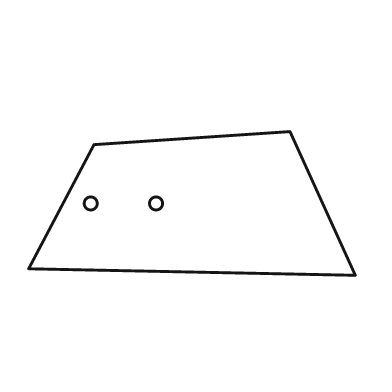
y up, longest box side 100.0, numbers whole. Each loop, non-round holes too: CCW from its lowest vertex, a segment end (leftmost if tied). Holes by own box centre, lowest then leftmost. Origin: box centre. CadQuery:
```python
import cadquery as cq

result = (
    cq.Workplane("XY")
    .moveTo(50.0, -22.0)
    .lineTo(30.0, 22.0)
    .lineTo(-30.0, 18.0)
    .lineTo(-50.0, -20.0)
    .close()
    .moveTo(-31.0, 0.0)
    .circle(2.0)
    .moveTo(-11.0, 0.0)
    .circle(2.0)
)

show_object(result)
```